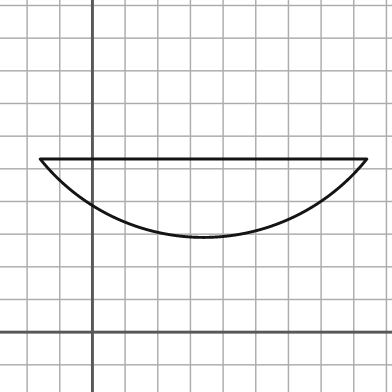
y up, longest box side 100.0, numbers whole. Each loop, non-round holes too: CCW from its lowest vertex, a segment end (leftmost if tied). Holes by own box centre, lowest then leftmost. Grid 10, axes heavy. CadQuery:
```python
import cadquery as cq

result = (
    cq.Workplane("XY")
    .moveTo(-16.0, 53.0)
    .threePointArc((34.0, 29.0), (84.0, 53.0))
    .close()
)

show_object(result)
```